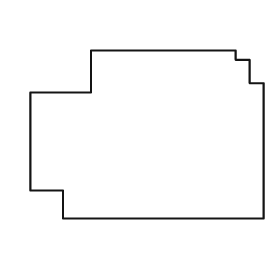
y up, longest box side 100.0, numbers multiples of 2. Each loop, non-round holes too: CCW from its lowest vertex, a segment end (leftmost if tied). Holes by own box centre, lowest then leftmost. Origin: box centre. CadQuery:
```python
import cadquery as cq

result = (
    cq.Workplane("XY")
    .moveTo(-36.0, -36.0)
    .lineTo(50.0, -36.0)
    .lineTo(50.0, 22.0)
    .lineTo(44.0, 22.0)
    .lineTo(44.0, 32.0)
    .lineTo(38.0, 32.0)
    .lineTo(38.0, 36.0)
    .lineTo(-24.0, 36.0)
    .lineTo(-24.0, 18.0)
    .lineTo(-50.0, 18.0)
    .lineTo(-50.0, -24.0)
    .lineTo(-36.0, -24.0)
    .close()
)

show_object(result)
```